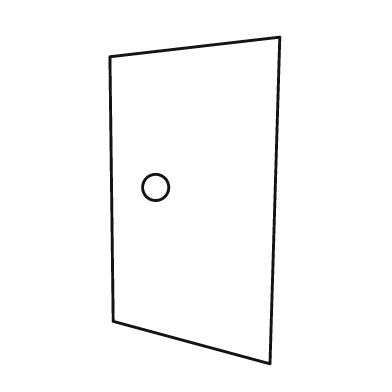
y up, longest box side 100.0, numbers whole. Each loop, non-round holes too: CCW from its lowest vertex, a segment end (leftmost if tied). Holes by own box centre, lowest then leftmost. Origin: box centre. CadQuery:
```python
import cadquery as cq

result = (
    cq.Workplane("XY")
    .moveTo(23.0, -50.0)
    .lineTo(26.0, 50.0)
    .lineTo(-26.0, 44.0)
    .lineTo(-25.0, -37.0)
    .close()
    .moveTo(-12.0, 4.0)
    .circle(4.0)
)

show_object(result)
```